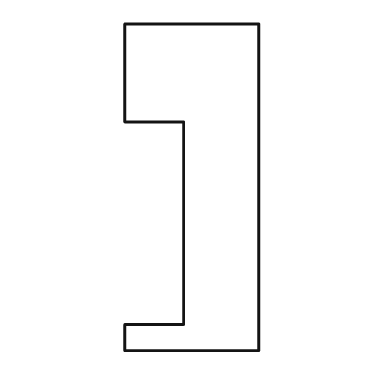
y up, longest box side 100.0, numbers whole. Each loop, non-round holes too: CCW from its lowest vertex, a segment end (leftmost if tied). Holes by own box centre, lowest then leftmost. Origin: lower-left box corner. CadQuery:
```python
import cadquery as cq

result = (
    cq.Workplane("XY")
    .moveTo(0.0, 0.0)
    .lineTo(41.0, 0.0)
    .lineTo(41.0, 100.0)
    .lineTo(0.0, 100.0)
    .lineTo(0.0, 70.0)
    .lineTo(18.0, 70.0)
    .lineTo(18.0, 8.0)
    .lineTo(0.0, 8.0)
    .close()
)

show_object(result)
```